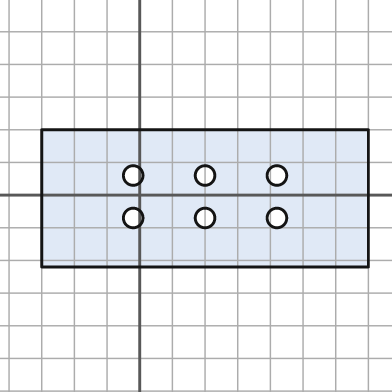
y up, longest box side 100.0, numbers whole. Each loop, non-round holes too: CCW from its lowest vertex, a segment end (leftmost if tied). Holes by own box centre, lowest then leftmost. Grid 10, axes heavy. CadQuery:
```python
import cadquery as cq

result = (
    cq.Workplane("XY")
    .moveTo(-30.0, -22.0)
    .lineTo(70.0, -22.0)
    .lineTo(70.0, 20.0)
    .lineTo(-30.0, 20.0)
    .close()
    .moveTo(-2.0, -7.0)
    .circle(3.0)
    .moveTo(20.0, -7.0)
    .circle(3.0)
    .moveTo(42.0, -7.0)
    .circle(3.0)
    .moveTo(-2.0, 6.0)
    .circle(3.0)
    .moveTo(20.0, 6.0)
    .circle(3.0)
    .moveTo(42.0, 6.0)
    .circle(3.0)
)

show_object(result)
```